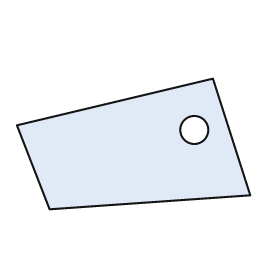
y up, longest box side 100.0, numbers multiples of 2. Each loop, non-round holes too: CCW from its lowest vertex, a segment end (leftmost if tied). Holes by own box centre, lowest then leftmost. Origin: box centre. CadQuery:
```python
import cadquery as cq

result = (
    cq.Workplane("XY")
    .moveTo(-36.0, -28.0)
    .lineTo(50.0, -22.0)
    .lineTo(34.0, 28.0)
    .lineTo(-50.0, 8.0)
    .close()
    .moveTo(26.0, 6.0)
    .circle(6.0)
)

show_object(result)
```